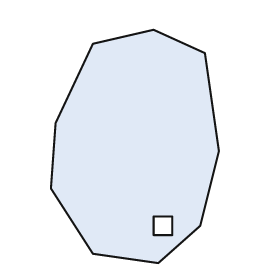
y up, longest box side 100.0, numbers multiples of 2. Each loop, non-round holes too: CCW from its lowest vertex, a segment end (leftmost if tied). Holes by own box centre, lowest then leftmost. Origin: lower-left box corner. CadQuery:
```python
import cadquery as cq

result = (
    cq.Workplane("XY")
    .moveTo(46.0, 0.0)
    .lineTo(64.0, 16.0)
    .lineTo(72.0, 48.0)
    .lineTo(66.0, 90.0)
    .lineTo(44.0, 100.0)
    .lineTo(18.0, 94.0)
    .lineTo(2.0, 60.0)
    .lineTo(0.0, 32.0)
    .lineTo(18.0, 4.0)
    .close()
    .moveTo(44.0, 12.0)
    .lineTo(52.0, 12.0)
    .lineTo(52.0, 20.0)
    .lineTo(44.0, 20.0)
    .close()
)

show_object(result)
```